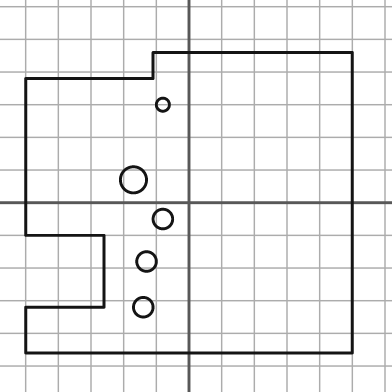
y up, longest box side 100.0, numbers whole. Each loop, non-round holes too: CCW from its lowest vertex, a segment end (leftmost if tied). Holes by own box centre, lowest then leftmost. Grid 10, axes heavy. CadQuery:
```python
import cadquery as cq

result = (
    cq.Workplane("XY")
    .moveTo(-50.0, -46.0)
    .lineTo(50.0, -46.0)
    .lineTo(50.0, 46.0)
    .lineTo(-11.0, 46.0)
    .lineTo(-11.0, 38.0)
    .lineTo(-50.0, 38.0)
    .lineTo(-50.0, -10.0)
    .lineTo(-26.0, -10.0)
    .lineTo(-26.0, -32.0)
    .lineTo(-50.0, -32.0)
    .close()
    .moveTo(-14.0, -32.0)
    .circle(3.0)
    .moveTo(-13.0, -18.0)
    .circle(3.0)
    .moveTo(-8.0, -5.0)
    .circle(3.0)
    .moveTo(-17.0, 7.0)
    .circle(4.0)
    .moveTo(-8.0, 30.0)
    .circle(2.0)
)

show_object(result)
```